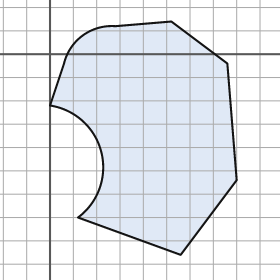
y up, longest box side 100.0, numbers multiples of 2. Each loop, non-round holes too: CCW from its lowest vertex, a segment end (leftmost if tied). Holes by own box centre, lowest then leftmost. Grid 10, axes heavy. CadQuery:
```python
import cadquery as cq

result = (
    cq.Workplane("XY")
    .moveTo(56.0, -86.0)
    .lineTo(80.0, -54.0)
    .lineTo(76.0, -4.0)
    .lineTo(52.0, 14.0)
    .lineTo(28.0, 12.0)
    .threePointArc((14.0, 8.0), (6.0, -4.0))
    .lineTo(0.0, -22.0)
    .threePointArc((22.0, -42.0), (12.0, -70.0))
    .close()
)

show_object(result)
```